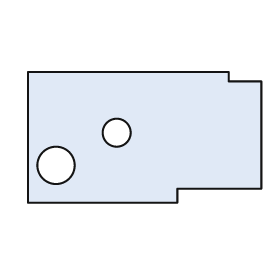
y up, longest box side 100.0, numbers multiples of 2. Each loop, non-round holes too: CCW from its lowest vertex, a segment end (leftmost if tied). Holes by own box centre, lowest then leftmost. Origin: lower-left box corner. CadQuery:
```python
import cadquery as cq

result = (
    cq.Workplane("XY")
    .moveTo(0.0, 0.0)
    .lineTo(64.0, 0.0)
    .lineTo(64.0, 6.0)
    .lineTo(100.0, 6.0)
    .lineTo(100.0, 52.0)
    .lineTo(86.0, 52.0)
    .lineTo(86.0, 56.0)
    .lineTo(0.0, 56.0)
    .close()
    .moveTo(12.0, 16.0)
    .circle(8.0)
    .moveTo(38.0, 30.0)
    .circle(6.0)
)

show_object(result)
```